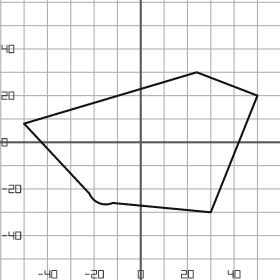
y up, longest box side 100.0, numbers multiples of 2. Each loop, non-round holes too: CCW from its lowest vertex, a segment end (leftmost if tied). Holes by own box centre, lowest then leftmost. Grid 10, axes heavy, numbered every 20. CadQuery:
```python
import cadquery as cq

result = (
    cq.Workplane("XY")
    .moveTo(30.0, -30.0)
    .lineTo(50.0, 20.0)
    .lineTo(24.0, 30.0)
    .lineTo(-50.0, 8.0)
    .lineTo(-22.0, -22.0)
    .threePointArc((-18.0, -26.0), (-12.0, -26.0))
    .close()
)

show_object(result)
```